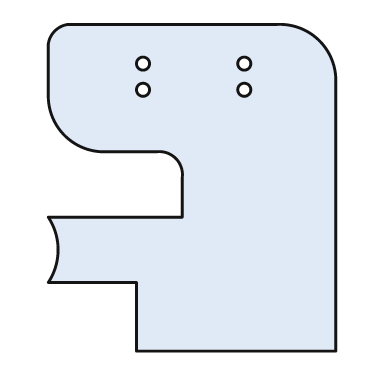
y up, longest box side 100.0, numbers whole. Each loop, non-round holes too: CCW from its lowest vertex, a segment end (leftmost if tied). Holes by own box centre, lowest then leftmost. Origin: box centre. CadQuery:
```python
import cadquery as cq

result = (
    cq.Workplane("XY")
    .moveTo(-17.0, -50.0)
    .lineTo(44.0, -50.0)
    .lineTo(44.0, 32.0)
    .threePointArc((39.0, 45.0), (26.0, 50.0))
    .lineTo(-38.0, 50.0)
    .threePointArc((-42.0, 48.0), (-44.0, 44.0))
    .lineTo(-44.0, 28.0)
    .threePointArc((-39.0, 16.0), (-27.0, 11.0))
    .lineTo(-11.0, 11.0)
    .threePointArc((-5.0, 9.0), (-3.0, 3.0))
    .lineTo(-3.0, -9.0)
    .lineTo(-44.0, -9.0)
    .threePointArc((-41.0, -19.0), (-44.0, -29.0))
    .lineTo(-17.0, -29.0)
    .close()
    .moveTo(-15.0, 30.0)
    .circle(2.0)
    .moveTo(16.0, 30.0)
    .circle(2.0)
    .moveTo(-15.0, 38.0)
    .circle(2.0)
    .moveTo(16.0, 38.0)
    .circle(2.0)
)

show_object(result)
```